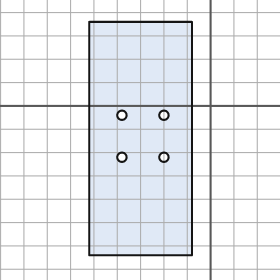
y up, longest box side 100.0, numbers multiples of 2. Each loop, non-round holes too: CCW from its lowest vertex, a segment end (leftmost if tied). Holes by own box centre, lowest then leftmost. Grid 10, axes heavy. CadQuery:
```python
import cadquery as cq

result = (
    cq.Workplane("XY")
    .moveTo(-52.0, -64.0)
    .lineTo(-8.0, -64.0)
    .lineTo(-8.0, 36.0)
    .lineTo(-52.0, 36.0)
    .close()
    .moveTo(-38.0, -22.0)
    .circle(2.0)
    .moveTo(-20.0, -22.0)
    .circle(2.0)
    .moveTo(-38.0, -4.0)
    .circle(2.0)
    .moveTo(-20.0, -4.0)
    .circle(2.0)
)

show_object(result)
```